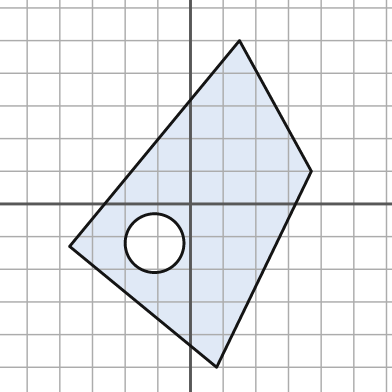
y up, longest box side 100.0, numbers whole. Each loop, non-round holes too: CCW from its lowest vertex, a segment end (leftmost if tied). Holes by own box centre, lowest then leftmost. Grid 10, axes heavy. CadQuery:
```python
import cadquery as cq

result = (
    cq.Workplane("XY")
    .moveTo(8.0, -50.0)
    .lineTo(37.0, 10.0)
    .lineTo(15.0, 50.0)
    .lineTo(-37.0, -13.0)
    .close()
    .moveTo(-11.0, -12.0)
    .circle(9.0)
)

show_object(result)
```